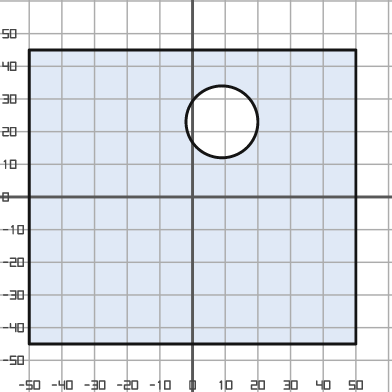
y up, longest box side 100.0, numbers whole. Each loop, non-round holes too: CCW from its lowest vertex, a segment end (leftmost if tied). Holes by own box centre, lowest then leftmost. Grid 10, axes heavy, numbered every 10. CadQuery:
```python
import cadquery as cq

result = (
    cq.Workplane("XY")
    .moveTo(-50.0, -45.0)
    .lineTo(50.0, -45.0)
    .lineTo(50.0, 45.0)
    .lineTo(-50.0, 45.0)
    .close()
    .moveTo(9.0, 23.0)
    .circle(11.0)
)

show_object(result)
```